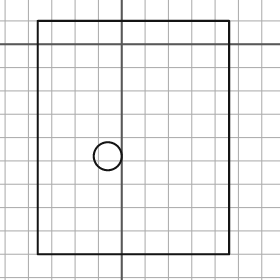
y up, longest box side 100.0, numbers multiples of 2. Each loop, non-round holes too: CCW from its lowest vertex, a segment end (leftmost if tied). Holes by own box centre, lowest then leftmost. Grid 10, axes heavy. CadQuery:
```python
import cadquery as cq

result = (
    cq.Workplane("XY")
    .moveTo(-36.0, -90.0)
    .lineTo(46.0, -90.0)
    .lineTo(46.0, 10.0)
    .lineTo(-36.0, 10.0)
    .close()
    .moveTo(-6.0, -48.0)
    .circle(6.0)
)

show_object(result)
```